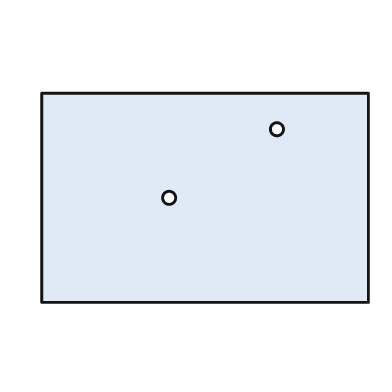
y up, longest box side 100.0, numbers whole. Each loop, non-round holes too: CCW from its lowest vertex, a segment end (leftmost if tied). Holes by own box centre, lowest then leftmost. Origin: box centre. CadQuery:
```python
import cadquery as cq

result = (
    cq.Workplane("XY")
    .moveTo(-50.0, -32.0)
    .lineTo(50.0, -32.0)
    .lineTo(50.0, 32.0)
    .lineTo(-50.0, 32.0)
    .close()
    .moveTo(-11.0, 0.0)
    .circle(2.0)
    .moveTo(22.0, 21.0)
    .circle(2.0)
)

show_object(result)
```